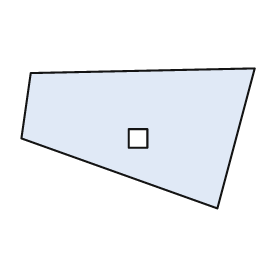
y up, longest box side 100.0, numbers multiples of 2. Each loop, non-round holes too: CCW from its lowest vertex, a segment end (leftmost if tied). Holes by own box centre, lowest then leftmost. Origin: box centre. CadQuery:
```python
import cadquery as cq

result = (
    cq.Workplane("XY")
    .moveTo(34.0, -30.0)
    .lineTo(50.0, 30.0)
    .lineTo(-46.0, 28.0)
    .lineTo(-50.0, 0.0)
    .close()
    .moveTo(-4.0, -4.0)
    .lineTo(4.0, -4.0)
    .lineTo(4.0, 4.0)
    .lineTo(-4.0, 4.0)
    .close()
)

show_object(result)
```